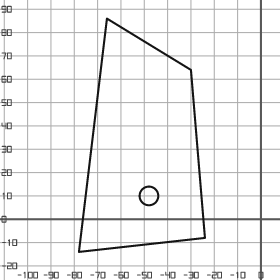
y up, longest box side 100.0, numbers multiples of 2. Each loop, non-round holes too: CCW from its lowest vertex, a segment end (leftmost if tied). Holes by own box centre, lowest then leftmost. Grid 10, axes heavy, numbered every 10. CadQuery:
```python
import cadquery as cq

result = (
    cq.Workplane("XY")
    .moveTo(-78.0, -14.0)
    .lineTo(-24.0, -8.0)
    .lineTo(-30.0, 64.0)
    .lineTo(-66.0, 86.0)
    .close()
    .moveTo(-48.0, 10.0)
    .circle(4.0)
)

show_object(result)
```